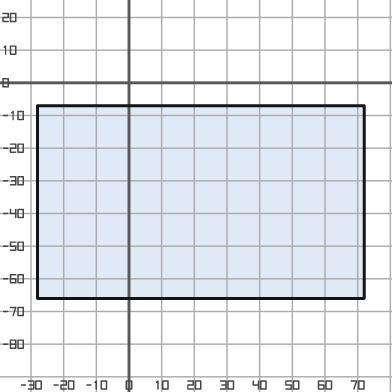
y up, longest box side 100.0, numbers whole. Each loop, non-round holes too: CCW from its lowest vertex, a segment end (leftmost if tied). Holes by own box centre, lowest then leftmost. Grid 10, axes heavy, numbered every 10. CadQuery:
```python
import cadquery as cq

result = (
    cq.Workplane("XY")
    .moveTo(-28.0, -66.0)
    .lineTo(72.0, -66.0)
    .lineTo(72.0, -7.0)
    .lineTo(-28.0, -7.0)
    .close()
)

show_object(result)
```